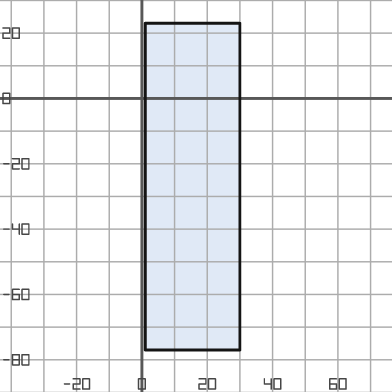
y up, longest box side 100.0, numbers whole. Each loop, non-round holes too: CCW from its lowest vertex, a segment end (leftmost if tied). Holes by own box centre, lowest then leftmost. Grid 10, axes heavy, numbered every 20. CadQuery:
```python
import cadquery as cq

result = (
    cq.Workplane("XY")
    .moveTo(1.0, -77.0)
    .lineTo(30.0, -77.0)
    .lineTo(30.0, 23.0)
    .lineTo(1.0, 23.0)
    .close()
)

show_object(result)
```